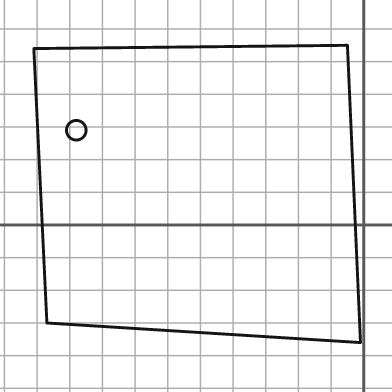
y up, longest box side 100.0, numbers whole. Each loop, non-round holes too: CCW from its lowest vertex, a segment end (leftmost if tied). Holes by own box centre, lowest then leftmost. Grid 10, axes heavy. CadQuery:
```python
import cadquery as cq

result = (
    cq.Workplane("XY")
    .moveTo(-1.0, -36.0)
    .lineTo(-5.0, 55.0)
    .lineTo(-101.0, 54.0)
    .lineTo(-97.0, -30.0)
    .close()
    .moveTo(-88.0, 29.0)
    .circle(3.0)
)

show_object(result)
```